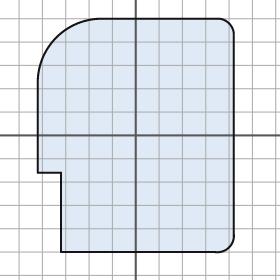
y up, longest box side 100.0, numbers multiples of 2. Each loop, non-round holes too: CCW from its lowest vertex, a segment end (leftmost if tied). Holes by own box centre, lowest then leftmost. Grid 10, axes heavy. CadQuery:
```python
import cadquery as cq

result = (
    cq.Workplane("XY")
    .moveTo(-32.0, -50.0)
    .lineTo(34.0, -50.0)
    .threePointArc((40.0, -48.0), (42.0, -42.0))
    .lineTo(42.0, 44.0)
    .threePointArc((40.0, 48.0), (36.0, 50.0))
    .lineTo(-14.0, 50.0)
    .threePointArc((-34.0, 42.0), (-42.0, 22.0))
    .lineTo(-42.0, -16.0)
    .lineTo(-32.0, -16.0)
    .close()
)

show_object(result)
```